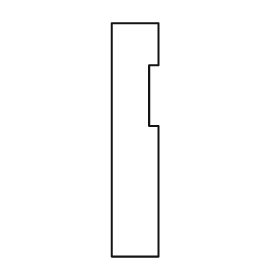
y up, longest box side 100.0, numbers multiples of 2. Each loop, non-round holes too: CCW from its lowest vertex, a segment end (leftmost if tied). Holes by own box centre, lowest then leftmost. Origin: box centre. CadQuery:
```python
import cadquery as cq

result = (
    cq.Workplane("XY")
    .moveTo(-10.0, -50.0)
    .lineTo(10.0, -50.0)
    .lineTo(10.0, 6.0)
    .lineTo(6.0, 6.0)
    .lineTo(6.0, 32.0)
    .lineTo(10.0, 32.0)
    .lineTo(10.0, 50.0)
    .lineTo(-10.0, 50.0)
    .close()
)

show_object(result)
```